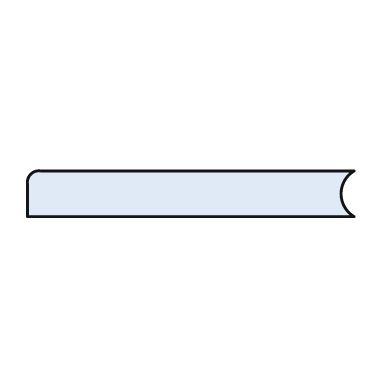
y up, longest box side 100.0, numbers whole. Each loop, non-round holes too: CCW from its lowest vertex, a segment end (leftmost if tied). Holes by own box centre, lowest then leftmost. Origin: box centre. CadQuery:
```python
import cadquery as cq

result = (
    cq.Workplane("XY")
    .moveTo(-50.0, -7.0)
    .lineTo(50.0, -7.0)
    .threePointArc((46.0, 0.0), (50.0, 7.0))
    .lineTo(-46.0, 7.0)
    .threePointArc((-49.0, 6.0), (-50.0, 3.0))
    .close()
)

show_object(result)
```